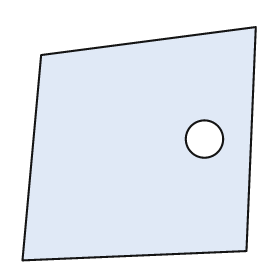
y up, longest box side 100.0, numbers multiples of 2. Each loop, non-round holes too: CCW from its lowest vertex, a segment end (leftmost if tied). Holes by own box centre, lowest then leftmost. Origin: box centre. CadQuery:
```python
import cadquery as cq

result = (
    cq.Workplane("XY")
    .moveTo(-50.0, -50.0)
    .lineTo(46.0, -46.0)
    .lineTo(50.0, 50.0)
    .lineTo(-42.0, 38.0)
    .close()
    .moveTo(28.0, 2.0)
    .circle(8.0)
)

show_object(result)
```